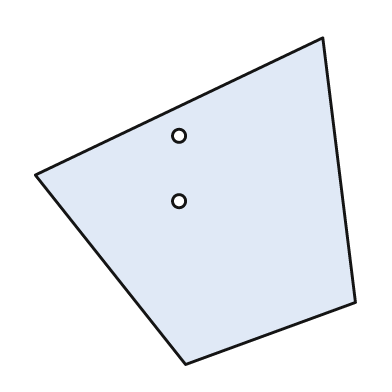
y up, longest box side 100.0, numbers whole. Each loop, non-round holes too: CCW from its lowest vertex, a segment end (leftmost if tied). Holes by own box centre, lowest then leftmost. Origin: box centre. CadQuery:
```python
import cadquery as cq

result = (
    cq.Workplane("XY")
    .moveTo(-3.0, -50.0)
    .lineTo(49.0, -31.0)
    .lineTo(39.0, 50.0)
    .lineTo(-49.0, 8.0)
    .close()
    .moveTo(-5.0, 0.0)
    .circle(2.0)
    .moveTo(-5.0, 20.0)
    .circle(2.0)
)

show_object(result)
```